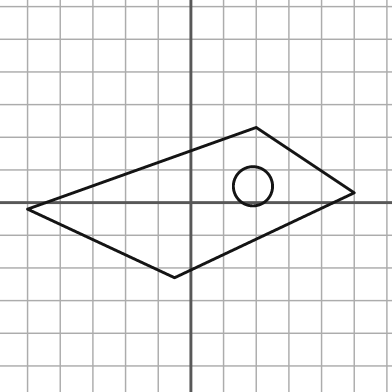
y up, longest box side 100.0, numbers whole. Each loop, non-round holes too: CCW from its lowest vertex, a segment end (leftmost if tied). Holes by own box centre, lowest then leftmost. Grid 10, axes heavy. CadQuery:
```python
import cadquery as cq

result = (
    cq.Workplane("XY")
    .moveTo(-5.0, -23.0)
    .lineTo(50.0, 3.0)
    .lineTo(20.0, 23.0)
    .lineTo(-50.0, -2.0)
    .close()
    .moveTo(19.0, 5.0)
    .circle(6.0)
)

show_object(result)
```